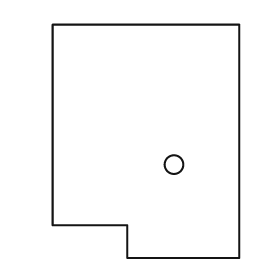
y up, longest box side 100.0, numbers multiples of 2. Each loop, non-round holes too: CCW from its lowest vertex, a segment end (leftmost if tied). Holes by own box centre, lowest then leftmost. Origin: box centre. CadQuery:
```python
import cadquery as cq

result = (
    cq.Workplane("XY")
    .moveTo(-8.0, -50.0)
    .lineTo(40.0, -50.0)
    .lineTo(40.0, 50.0)
    .lineTo(-40.0, 50.0)
    .lineTo(-40.0, -36.0)
    .lineTo(-8.0, -36.0)
    .close()
    .moveTo(12.0, -10.0)
    .circle(4.0)
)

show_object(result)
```